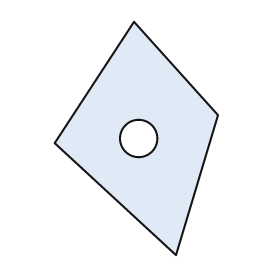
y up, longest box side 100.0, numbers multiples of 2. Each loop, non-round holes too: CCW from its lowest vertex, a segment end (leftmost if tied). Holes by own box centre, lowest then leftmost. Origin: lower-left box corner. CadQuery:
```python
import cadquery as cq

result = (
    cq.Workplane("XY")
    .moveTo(52.0, 0.0)
    .lineTo(70.0, 60.0)
    .lineTo(34.0, 100.0)
    .lineTo(0.0, 48.0)
    .close()
    .moveTo(36.0, 50.0)
    .circle(8.0)
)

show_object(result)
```